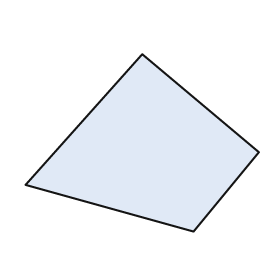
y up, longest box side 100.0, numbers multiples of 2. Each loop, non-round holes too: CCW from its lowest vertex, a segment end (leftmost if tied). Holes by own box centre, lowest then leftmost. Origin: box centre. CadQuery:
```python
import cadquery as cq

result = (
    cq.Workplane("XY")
    .moveTo(22.0, -38.0)
    .lineTo(50.0, -4.0)
    .lineTo(0.0, 38.0)
    .lineTo(-50.0, -18.0)
    .close()
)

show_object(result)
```